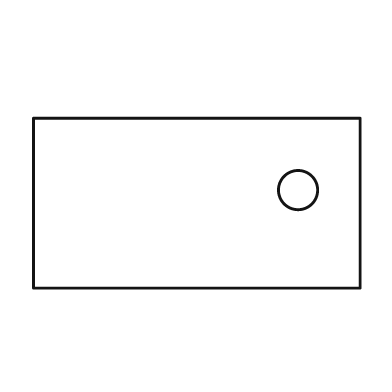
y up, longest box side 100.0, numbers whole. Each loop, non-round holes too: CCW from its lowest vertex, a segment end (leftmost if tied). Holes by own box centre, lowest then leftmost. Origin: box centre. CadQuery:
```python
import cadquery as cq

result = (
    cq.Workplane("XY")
    .moveTo(-50.0, -26.0)
    .lineTo(50.0, -26.0)
    .lineTo(50.0, 26.0)
    .lineTo(-50.0, 26.0)
    .close()
    .moveTo(31.0, 4.0)
    .circle(6.0)
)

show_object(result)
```